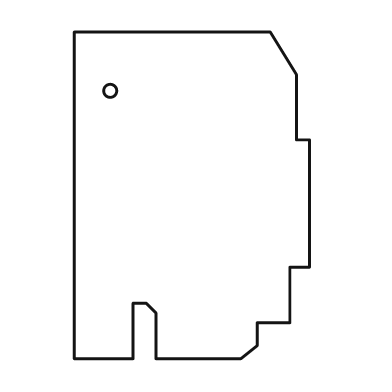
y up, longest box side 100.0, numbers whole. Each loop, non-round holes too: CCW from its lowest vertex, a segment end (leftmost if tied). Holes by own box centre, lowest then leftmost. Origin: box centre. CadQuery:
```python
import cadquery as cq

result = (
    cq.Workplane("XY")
    .moveTo(-36.0, -50.0)
    .lineTo(-18.0, -50.0)
    .lineTo(-18.0, -33.0)
    .lineTo(-14.0, -33.0)
    .lineTo(-11.0, -36.0)
    .lineTo(-11.0, -50.0)
    .lineTo(15.0, -50.0)
    .lineTo(20.0, -46.0)
    .lineTo(20.0, -39.0)
    .lineTo(30.0, -39.0)
    .lineTo(30.0, -22.0)
    .lineTo(36.0, -22.0)
    .lineTo(36.0, 17.0)
    .lineTo(32.0, 17.0)
    .lineTo(32.0, 37.0)
    .lineTo(24.0, 50.0)
    .lineTo(-36.0, 50.0)
    .close()
    .moveTo(-25.0, 32.0)
    .circle(2.0)
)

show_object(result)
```